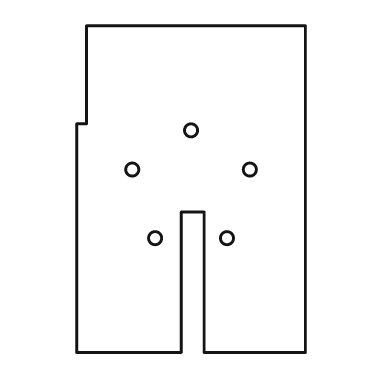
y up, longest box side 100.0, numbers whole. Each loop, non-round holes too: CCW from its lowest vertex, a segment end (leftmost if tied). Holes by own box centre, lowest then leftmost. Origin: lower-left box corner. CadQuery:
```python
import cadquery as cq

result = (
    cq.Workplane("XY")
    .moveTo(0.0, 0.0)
    .lineTo(32.0, 0.0)
    .lineTo(32.0, 43.0)
    .lineTo(39.0, 43.0)
    .lineTo(39.0, 0.0)
    .lineTo(70.0, 0.0)
    .lineTo(70.0, 100.0)
    .lineTo(3.0, 100.0)
    .lineTo(3.0, 70.0)
    .lineTo(0.0, 70.0)
    .close()
    .moveTo(24.0, 35.0)
    .circle(2.0)
    .moveTo(46.0, 35.0)
    .circle(2.0)
    .moveTo(17.0, 56.0)
    .circle(2.0)
    .moveTo(53.0, 56.0)
    .circle(2.0)
    .moveTo(35.0, 68.0)
    .circle(2.0)
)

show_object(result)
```